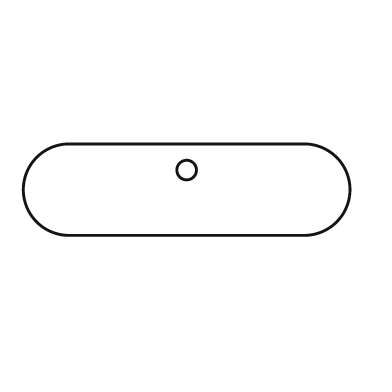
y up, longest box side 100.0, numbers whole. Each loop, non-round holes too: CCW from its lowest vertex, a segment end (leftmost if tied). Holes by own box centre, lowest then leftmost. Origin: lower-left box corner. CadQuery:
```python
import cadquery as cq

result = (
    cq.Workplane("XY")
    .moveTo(14.0, 0.0)
    .lineTo(86.0, 0.0)
    .threePointArc((100.0, 14.0), (86.0, 28.0))
    .lineTo(14.0, 28.0)
    .threePointArc((0.0, 14.0), (14.0, 0.0))
    .close()
    .moveTo(50.0, 20.0)
    .circle(3.0)
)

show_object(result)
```